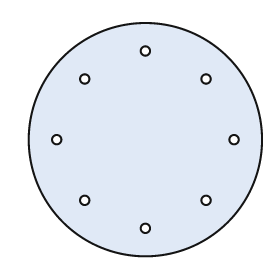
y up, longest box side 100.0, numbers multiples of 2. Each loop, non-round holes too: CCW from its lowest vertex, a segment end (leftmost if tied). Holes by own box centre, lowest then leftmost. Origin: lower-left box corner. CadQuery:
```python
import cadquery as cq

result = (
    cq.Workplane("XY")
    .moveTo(50.0, 50.0)
    .circle(50.0)
    .moveTo(50.0, 12.0)
    .circle(2.0)
    .moveTo(24.0, 24.0)
    .circle(2.0)
    .moveTo(76.0, 24.0)
    .circle(2.0)
    .moveTo(12.0, 50.0)
    .circle(2.0)
    .moveTo(88.0, 50.0)
    .circle(2.0)
    .moveTo(24.0, 76.0)
    .circle(2.0)
    .moveTo(76.0, 76.0)
    .circle(2.0)
    .moveTo(50.0, 88.0)
    .circle(2.0)
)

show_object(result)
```